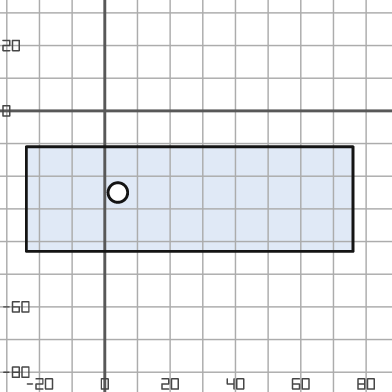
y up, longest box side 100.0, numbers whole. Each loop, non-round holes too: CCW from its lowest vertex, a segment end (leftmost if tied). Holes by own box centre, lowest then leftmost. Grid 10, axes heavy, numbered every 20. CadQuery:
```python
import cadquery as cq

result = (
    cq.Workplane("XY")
    .moveTo(-24.0, -43.0)
    .lineTo(76.0, -43.0)
    .lineTo(76.0, -11.0)
    .lineTo(-24.0, -11.0)
    .close()
    .moveTo(4.0, -25.0)
    .circle(3.0)
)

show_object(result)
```